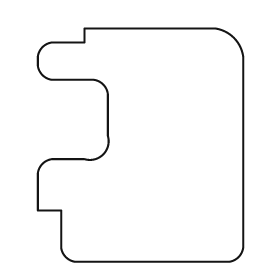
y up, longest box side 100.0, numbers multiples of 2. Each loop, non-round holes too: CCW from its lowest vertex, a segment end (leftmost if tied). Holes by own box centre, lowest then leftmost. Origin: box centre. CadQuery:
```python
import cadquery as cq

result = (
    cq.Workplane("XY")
    .moveTo(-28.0, -50.0)
    .lineTo(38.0, -50.0)
    .threePointArc((42.0, -48.0), (44.0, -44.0))
    .lineTo(44.0, 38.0)
    .threePointArc((40.0, 46.0), (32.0, 50.0))
    .lineTo(-24.0, 50.0)
    .lineTo(-24.0, 44.0)
    .lineTo(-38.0, 44.0)
    .threePointArc((-42.0, 42.0), (-44.0, 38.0))
    .lineTo(-44.0, 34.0)
    .threePointArc((-42.0, 30.0), (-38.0, 28.0))
    .lineTo(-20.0, 28.0)
    .threePointArc((-16.0, 26.0), (-14.0, 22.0))
    .lineTo(-14.0, 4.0)
    .threePointArc((-16.0, -4.0), (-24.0, -6.0))
    .lineTo(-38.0, -6.0)
    .threePointArc((-42.0, -8.0), (-44.0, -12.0))
    .lineTo(-44.0, -28.0)
    .lineTo(-34.0, -28.0)
    .lineTo(-34.0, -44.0)
    .threePointArc((-32.0, -48.0), (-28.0, -50.0))
    .close()
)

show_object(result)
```